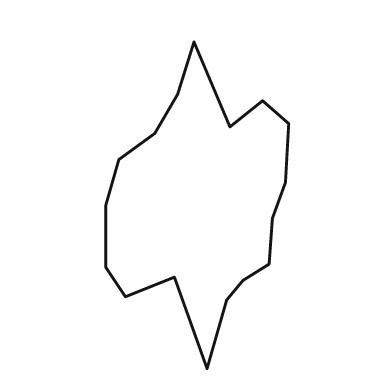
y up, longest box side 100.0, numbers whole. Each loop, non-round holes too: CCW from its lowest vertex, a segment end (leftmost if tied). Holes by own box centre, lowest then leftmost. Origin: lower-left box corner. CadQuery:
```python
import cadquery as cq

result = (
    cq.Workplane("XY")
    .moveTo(31.0, 0.0)
    .lineTo(37.0, 21.0)
    .lineTo(42.0, 27.0)
    .lineTo(50.0, 32.0)
    .lineTo(51.0, 46.0)
    .lineTo(55.0, 57.0)
    .lineTo(56.0, 75.0)
    .lineTo(48.0, 82.0)
    .lineTo(38.0, 74.0)
    .lineTo(27.0, 100.0)
    .lineTo(22.0, 84.0)
    .lineTo(15.0, 72.0)
    .lineTo(4.0, 64.0)
    .lineTo(0.0, 50.0)
    .lineTo(0.0, 31.0)
    .lineTo(6.0, 22.0)
    .lineTo(21.0, 28.0)
    .close()
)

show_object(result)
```